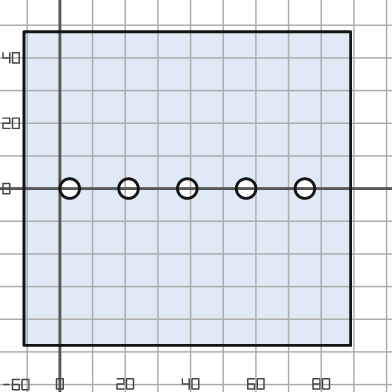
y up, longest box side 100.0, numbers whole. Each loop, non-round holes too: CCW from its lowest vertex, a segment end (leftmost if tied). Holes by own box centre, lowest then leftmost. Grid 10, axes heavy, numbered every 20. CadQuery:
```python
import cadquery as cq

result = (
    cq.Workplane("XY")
    .moveTo(-11.0, -48.0)
    .lineTo(89.0, -48.0)
    .lineTo(89.0, 48.0)
    .lineTo(-11.0, 48.0)
    .close()
    .moveTo(3.0, 0.0)
    .circle(3.0)
    .moveTo(21.0, 0.0)
    .circle(3.0)
    .moveTo(39.0, 0.0)
    .circle(3.0)
    .moveTo(57.0, 0.0)
    .circle(3.0)
    .moveTo(75.0, 0.0)
    .circle(3.0)
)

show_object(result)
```